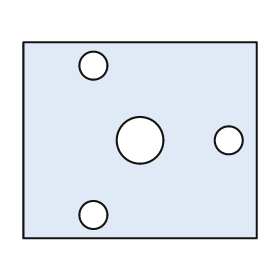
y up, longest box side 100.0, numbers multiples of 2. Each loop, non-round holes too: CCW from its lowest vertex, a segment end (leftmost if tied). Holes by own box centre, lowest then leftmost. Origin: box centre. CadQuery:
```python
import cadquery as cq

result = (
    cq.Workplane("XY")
    .moveTo(-50.0, -42.0)
    .lineTo(50.0, -42.0)
    .lineTo(50.0, 42.0)
    .lineTo(-50.0, 42.0)
    .close()
    .moveTo(-20.0, -32.0)
    .circle(6.0)
    .moveTo(0.0, 0.0)
    .circle(10.0)
    .moveTo(38.0, 0.0)
    .circle(6.0)
    .moveTo(-20.0, 32.0)
    .circle(6.0)
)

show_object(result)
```